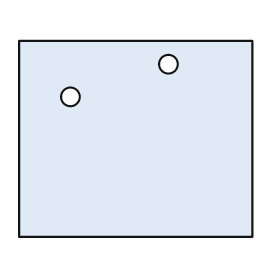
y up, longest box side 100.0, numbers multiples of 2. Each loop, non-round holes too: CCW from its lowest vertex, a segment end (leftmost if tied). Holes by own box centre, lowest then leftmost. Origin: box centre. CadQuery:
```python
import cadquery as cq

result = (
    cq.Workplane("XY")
    .moveTo(-50.0, -42.0)
    .lineTo(50.0, -42.0)
    .lineTo(50.0, 42.0)
    .lineTo(-50.0, 42.0)
    .close()
    .moveTo(-28.0, 18.0)
    .circle(4.0)
    .moveTo(14.0, 32.0)
    .circle(4.0)
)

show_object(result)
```